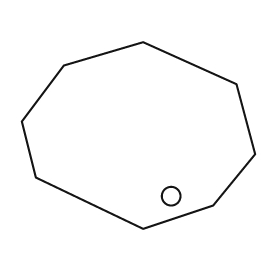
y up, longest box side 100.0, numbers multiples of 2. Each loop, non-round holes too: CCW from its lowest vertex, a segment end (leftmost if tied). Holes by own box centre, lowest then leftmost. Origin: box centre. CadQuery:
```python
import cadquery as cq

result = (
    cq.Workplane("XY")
    .moveTo(2.0, -40.0)
    .lineTo(32.0, -30.0)
    .lineTo(50.0, -8.0)
    .lineTo(42.0, 22.0)
    .lineTo(2.0, 40.0)
    .lineTo(-32.0, 30.0)
    .lineTo(-50.0, 6.0)
    .lineTo(-44.0, -18.0)
    .close()
    .moveTo(14.0, -26.0)
    .circle(4.0)
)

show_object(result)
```